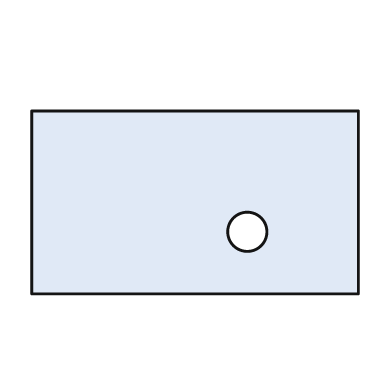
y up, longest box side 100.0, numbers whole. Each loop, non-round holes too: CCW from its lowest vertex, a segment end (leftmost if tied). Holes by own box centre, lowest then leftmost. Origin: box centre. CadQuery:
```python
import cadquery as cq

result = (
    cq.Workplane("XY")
    .moveTo(-50.0, -28.0)
    .lineTo(50.0, -28.0)
    .lineTo(50.0, 28.0)
    .lineTo(-50.0, 28.0)
    .close()
    .moveTo(16.0, -9.0)
    .circle(6.0)
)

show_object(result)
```